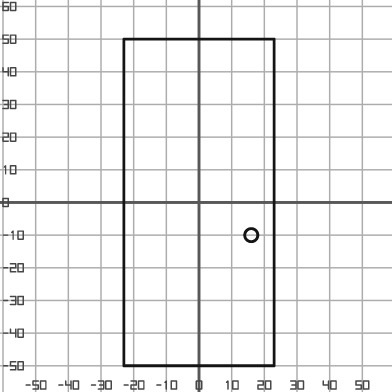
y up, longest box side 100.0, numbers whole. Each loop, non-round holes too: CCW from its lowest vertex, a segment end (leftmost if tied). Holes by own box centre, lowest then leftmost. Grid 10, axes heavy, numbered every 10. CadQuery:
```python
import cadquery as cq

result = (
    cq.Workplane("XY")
    .moveTo(-23.0, -50.0)
    .lineTo(23.0, -50.0)
    .lineTo(23.0, 50.0)
    .lineTo(-23.0, 50.0)
    .close()
    .moveTo(16.0, -10.0)
    .circle(2.0)
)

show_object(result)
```